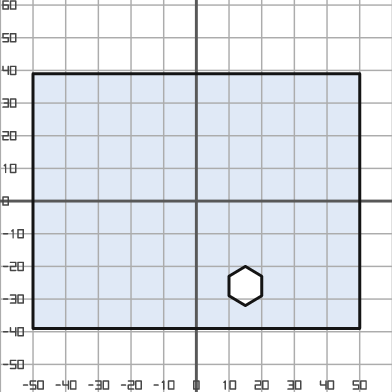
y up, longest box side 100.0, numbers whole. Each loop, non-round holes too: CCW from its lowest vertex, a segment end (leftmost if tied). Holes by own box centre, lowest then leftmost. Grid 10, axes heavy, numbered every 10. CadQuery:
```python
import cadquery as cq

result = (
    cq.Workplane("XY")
    .moveTo(-50.0, -39.0)
    .lineTo(50.0, -39.0)
    .lineTo(50.0, 39.0)
    .lineTo(-50.0, 39.0)
    .close()
    .moveTo(15.0, -32.0)
    .lineTo(20.0, -29.0)
    .lineTo(20.0, -23.0)
    .lineTo(15.0, -20.0)
    .lineTo(10.0, -23.0)
    .lineTo(10.0, -29.0)
    .close()
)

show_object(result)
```